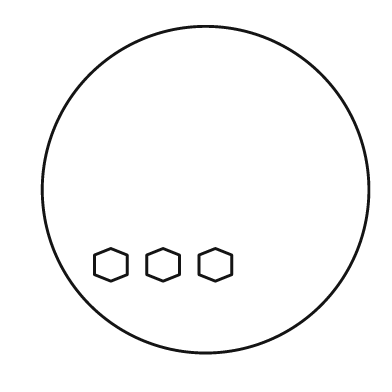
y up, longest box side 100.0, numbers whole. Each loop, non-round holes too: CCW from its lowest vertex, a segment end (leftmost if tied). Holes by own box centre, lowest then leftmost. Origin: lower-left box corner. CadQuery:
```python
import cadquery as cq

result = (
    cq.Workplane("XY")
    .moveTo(50.0, 50.0)
    .circle(50.0)
    .moveTo(21.0, 22.0)
    .lineTo(26.0, 24.0)
    .lineTo(26.0, 30.0)
    .lineTo(21.0, 32.0)
    .lineTo(16.0, 30.0)
    .lineTo(16.0, 24.0)
    .close()
    .moveTo(37.0, 22.0)
    .lineTo(42.0, 24.0)
    .lineTo(42.0, 30.0)
    .lineTo(37.0, 32.0)
    .lineTo(32.0, 30.0)
    .lineTo(32.0, 24.0)
    .close()
    .moveTo(53.0, 22.0)
    .lineTo(58.0, 24.0)
    .lineTo(58.0, 30.0)
    .lineTo(53.0, 32.0)
    .lineTo(48.0, 30.0)
    .lineTo(48.0, 24.0)
    .close()
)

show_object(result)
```